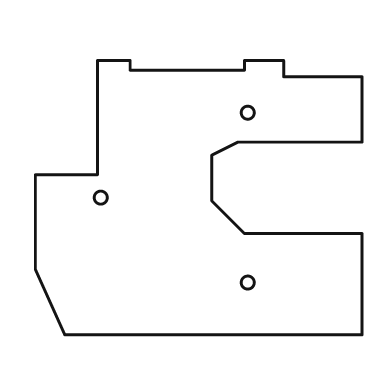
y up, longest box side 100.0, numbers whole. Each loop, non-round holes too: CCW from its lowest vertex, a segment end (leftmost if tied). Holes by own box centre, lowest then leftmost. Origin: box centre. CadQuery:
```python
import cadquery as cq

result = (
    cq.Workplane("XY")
    .moveTo(-41.0, -42.0)
    .lineTo(50.0, -42.0)
    .lineTo(50.0, -11.0)
    .lineTo(14.0, -11.0)
    .lineTo(4.0, -1.0)
    .lineTo(4.0, 13.0)
    .lineTo(12.0, 17.0)
    .lineTo(50.0, 17.0)
    .lineTo(50.0, 37.0)
    .lineTo(26.0, 37.0)
    .lineTo(26.0, 42.0)
    .lineTo(14.0, 42.0)
    .lineTo(14.0, 39.0)
    .lineTo(-21.0, 39.0)
    .lineTo(-21.0, 42.0)
    .lineTo(-31.0, 42.0)
    .lineTo(-31.0, 7.0)
    .lineTo(-50.0, 7.0)
    .lineTo(-50.0, -22.0)
    .close()
    .moveTo(15.0, -26.0)
    .circle(2.0)
    .moveTo(-30.0, 0.0)
    .circle(2.0)
    .moveTo(15.0, 26.0)
    .circle(2.0)
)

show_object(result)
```